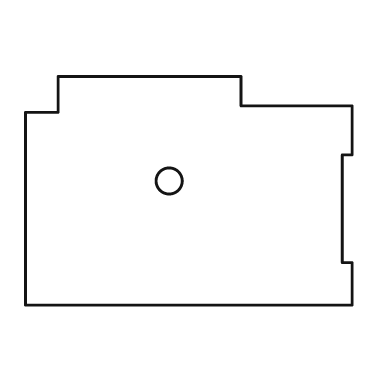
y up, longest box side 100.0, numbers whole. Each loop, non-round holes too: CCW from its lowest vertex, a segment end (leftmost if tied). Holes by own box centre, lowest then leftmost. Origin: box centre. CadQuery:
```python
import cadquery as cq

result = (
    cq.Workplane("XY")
    .moveTo(-50.0, -35.0)
    .lineTo(50.0, -35.0)
    .lineTo(50.0, -22.0)
    .lineTo(47.0, -22.0)
    .lineTo(47.0, 11.0)
    .lineTo(50.0, 11.0)
    .lineTo(50.0, 26.0)
    .lineTo(16.0, 26.0)
    .lineTo(16.0, 35.0)
    .lineTo(-40.0, 35.0)
    .lineTo(-40.0, 24.0)
    .lineTo(-50.0, 24.0)
    .close()
    .moveTo(-6.0, 3.0)
    .circle(4.0)
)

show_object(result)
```